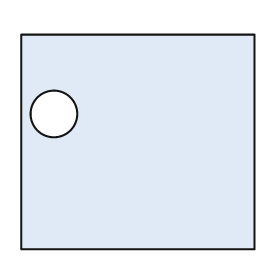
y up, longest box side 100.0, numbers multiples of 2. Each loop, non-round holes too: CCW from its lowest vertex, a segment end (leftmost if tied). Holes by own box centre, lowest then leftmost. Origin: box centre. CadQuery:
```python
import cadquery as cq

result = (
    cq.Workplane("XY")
    .moveTo(-50.0, -46.0)
    .lineTo(50.0, -46.0)
    .lineTo(50.0, 46.0)
    .lineTo(-50.0, 46.0)
    .close()
    .moveTo(-36.0, 12.0)
    .circle(10.0)
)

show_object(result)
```